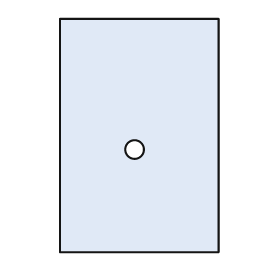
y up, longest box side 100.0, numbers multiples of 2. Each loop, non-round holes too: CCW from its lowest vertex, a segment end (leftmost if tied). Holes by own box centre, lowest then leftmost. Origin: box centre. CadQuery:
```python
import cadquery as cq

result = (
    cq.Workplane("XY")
    .moveTo(-34.0, -50.0)
    .lineTo(34.0, -50.0)
    .lineTo(34.0, 50.0)
    .lineTo(-34.0, 50.0)
    .close()
    .moveTo(-2.0, -6.0)
    .circle(4.0)
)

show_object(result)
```